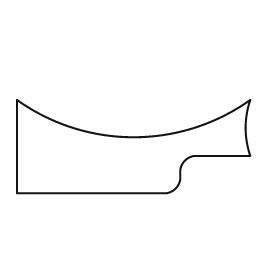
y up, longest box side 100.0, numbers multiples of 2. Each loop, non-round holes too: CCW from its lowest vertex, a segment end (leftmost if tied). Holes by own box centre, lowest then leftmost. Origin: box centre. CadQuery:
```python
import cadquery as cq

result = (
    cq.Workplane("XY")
    .moveTo(-50.0, -20.0)
    .lineTo(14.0, -20.0)
    .threePointArc((18.0, -18.0), (20.0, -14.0))
    .lineTo(20.0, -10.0)
    .threePointArc((22.0, -6.0), (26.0, -4.0))
    .lineTo(50.0, -4.0)
    .threePointArc((48.0, 8.0), (50.0, 20.0))
    .threePointArc((0.0, 4.0), (-50.0, 20.0))
    .close()
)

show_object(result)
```